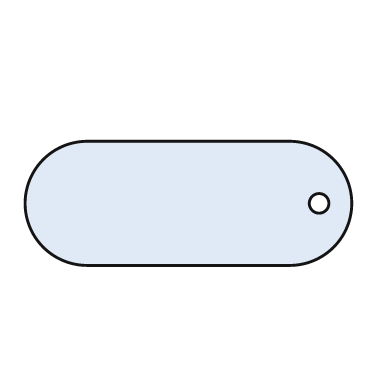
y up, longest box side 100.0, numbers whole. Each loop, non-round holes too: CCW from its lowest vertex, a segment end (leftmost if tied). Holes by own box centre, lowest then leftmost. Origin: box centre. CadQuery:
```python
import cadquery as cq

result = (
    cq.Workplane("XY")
    .moveTo(-31.0, -19.0)
    .lineTo(31.0, -19.0)
    .threePointArc((50.0, 0.0), (31.0, 19.0))
    .lineTo(-31.0, 19.0)
    .threePointArc((-50.0, 0.0), (-31.0, -19.0))
    .close()
    .moveTo(40.0, 0.0)
    .circle(3.0)
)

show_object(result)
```